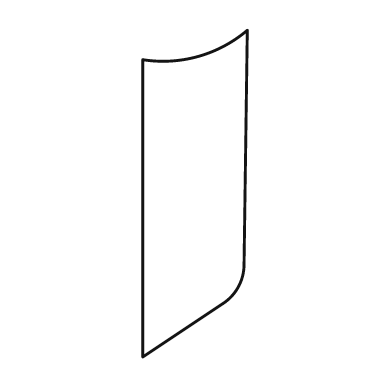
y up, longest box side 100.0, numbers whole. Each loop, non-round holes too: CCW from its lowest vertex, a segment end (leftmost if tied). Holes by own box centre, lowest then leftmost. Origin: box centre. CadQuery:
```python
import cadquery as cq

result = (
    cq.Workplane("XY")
    .moveTo(-16.0, -50.0)
    .lineTo(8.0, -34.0)
    .threePointArc((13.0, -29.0), (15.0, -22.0))
    .lineTo(16.0, 50.0)
    .threePointArc((1.0, 42.0), (-16.0, 41.0))
    .close()
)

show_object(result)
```